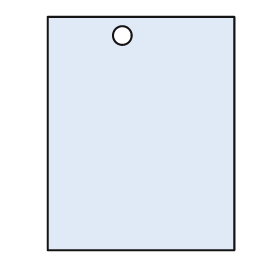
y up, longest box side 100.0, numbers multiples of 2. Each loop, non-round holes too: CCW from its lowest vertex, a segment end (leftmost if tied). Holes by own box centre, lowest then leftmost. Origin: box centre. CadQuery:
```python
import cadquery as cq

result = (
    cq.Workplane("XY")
    .moveTo(-40.0, -50.0)
    .lineTo(40.0, -50.0)
    .lineTo(40.0, 50.0)
    .lineTo(-40.0, 50.0)
    .close()
    .moveTo(-8.0, 42.0)
    .circle(4.0)
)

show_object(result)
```